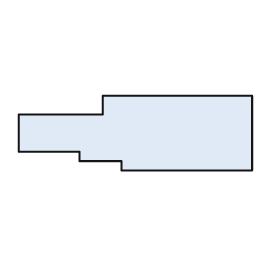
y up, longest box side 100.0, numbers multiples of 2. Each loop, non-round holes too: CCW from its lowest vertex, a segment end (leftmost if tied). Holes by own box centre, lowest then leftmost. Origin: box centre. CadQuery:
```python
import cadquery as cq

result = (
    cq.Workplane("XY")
    .moveTo(-6.0, -16.0)
    .lineTo(50.0, -16.0)
    .lineTo(50.0, 16.0)
    .lineTo(-14.0, 16.0)
    .lineTo(-14.0, 8.0)
    .lineTo(-50.0, 8.0)
    .lineTo(-50.0, -8.0)
    .lineTo(-24.0, -8.0)
    .lineTo(-24.0, -12.0)
    .lineTo(-6.0, -12.0)
    .close()
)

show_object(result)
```